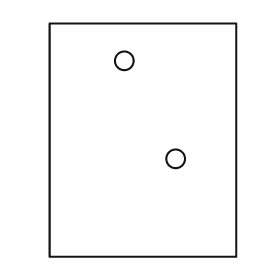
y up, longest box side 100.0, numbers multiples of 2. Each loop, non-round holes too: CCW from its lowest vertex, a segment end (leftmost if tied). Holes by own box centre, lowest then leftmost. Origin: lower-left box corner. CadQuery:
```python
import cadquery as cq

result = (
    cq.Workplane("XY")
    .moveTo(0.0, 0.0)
    .lineTo(80.0, 0.0)
    .lineTo(80.0, 100.0)
    .lineTo(0.0, 100.0)
    .close()
    .moveTo(54.0, 42.0)
    .circle(4.0)
    .moveTo(32.0, 84.0)
    .circle(4.0)
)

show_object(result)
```